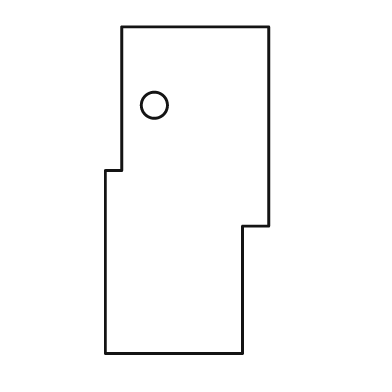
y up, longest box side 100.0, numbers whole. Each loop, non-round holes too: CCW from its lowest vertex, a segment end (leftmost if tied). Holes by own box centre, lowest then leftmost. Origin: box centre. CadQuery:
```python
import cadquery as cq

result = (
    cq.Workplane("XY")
    .moveTo(-25.0, -50.0)
    .lineTo(17.0, -50.0)
    .lineTo(17.0, -11.0)
    .lineTo(25.0, -11.0)
    .lineTo(25.0, 50.0)
    .lineTo(-20.0, 50.0)
    .lineTo(-20.0, 6.0)
    .lineTo(-25.0, 6.0)
    .close()
    .moveTo(-10.0, 26.0)
    .circle(4.0)
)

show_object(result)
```